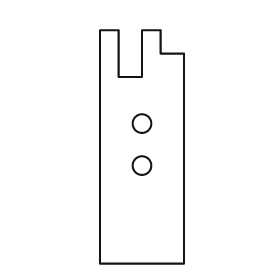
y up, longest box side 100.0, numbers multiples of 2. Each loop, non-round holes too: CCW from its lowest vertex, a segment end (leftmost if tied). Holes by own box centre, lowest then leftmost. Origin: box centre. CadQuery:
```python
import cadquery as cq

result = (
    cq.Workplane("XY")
    .moveTo(-18.0, -50.0)
    .lineTo(18.0, -50.0)
    .lineTo(18.0, 40.0)
    .lineTo(8.0, 40.0)
    .lineTo(8.0, 50.0)
    .lineTo(0.0, 50.0)
    .lineTo(0.0, 30.0)
    .lineTo(-10.0, 30.0)
    .lineTo(-10.0, 50.0)
    .lineTo(-18.0, 50.0)
    .close()
    .moveTo(0.0, -8.0)
    .circle(4.0)
    .moveTo(0.0, 10.0)
    .circle(4.0)
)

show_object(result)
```